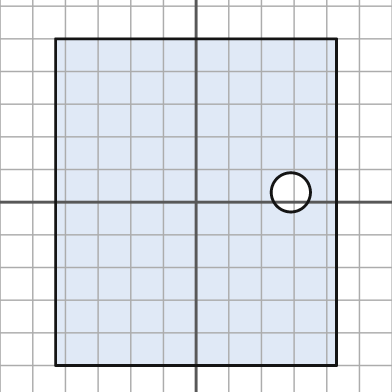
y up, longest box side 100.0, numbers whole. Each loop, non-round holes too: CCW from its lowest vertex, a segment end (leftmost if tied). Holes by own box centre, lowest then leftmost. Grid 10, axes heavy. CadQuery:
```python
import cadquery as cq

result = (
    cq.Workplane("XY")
    .moveTo(-43.0, -50.0)
    .lineTo(43.0, -50.0)
    .lineTo(43.0, 50.0)
    .lineTo(-43.0, 50.0)
    .close()
    .moveTo(29.0, 3.0)
    .circle(6.0)
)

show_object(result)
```